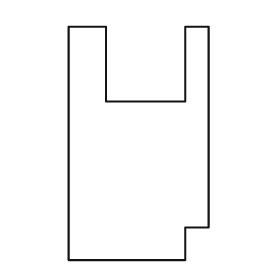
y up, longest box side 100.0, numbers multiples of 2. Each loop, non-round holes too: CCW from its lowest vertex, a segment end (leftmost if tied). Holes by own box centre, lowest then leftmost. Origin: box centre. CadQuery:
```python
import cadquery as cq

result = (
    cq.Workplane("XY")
    .moveTo(-30.0, -50.0)
    .lineTo(20.0, -50.0)
    .lineTo(20.0, -36.0)
    .lineTo(30.0, -36.0)
    .lineTo(30.0, 50.0)
    .lineTo(20.0, 50.0)
    .lineTo(20.0, 18.0)
    .lineTo(-14.0, 18.0)
    .lineTo(-14.0, 50.0)
    .lineTo(-30.0, 50.0)
    .close()
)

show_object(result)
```